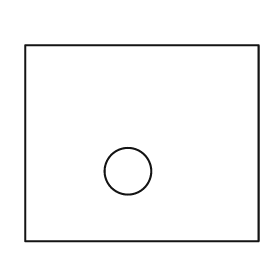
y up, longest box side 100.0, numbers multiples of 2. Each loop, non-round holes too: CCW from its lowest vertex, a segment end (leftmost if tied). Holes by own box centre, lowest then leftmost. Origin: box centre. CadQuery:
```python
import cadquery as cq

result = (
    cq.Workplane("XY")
    .moveTo(-50.0, -42.0)
    .lineTo(50.0, -42.0)
    .lineTo(50.0, 42.0)
    .lineTo(-50.0, 42.0)
    .close()
    .moveTo(-6.0, -12.0)
    .circle(10.0)
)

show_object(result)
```